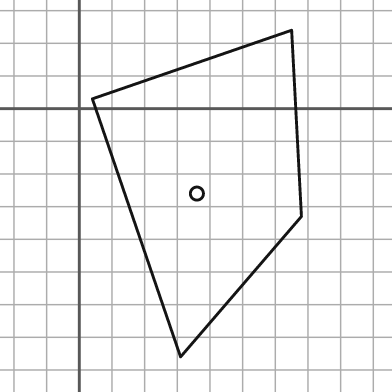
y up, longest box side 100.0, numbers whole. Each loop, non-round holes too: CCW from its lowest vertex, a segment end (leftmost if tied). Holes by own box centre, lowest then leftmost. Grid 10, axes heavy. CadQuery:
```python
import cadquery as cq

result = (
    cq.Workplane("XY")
    .moveTo(31.0, -76.0)
    .lineTo(68.0, -33.0)
    .lineTo(65.0, 24.0)
    .lineTo(4.0, 3.0)
    .close()
    .moveTo(36.0, -26.0)
    .circle(2.0)
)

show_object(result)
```